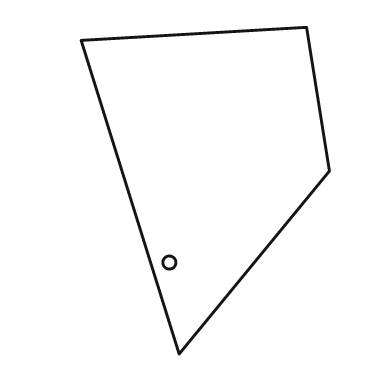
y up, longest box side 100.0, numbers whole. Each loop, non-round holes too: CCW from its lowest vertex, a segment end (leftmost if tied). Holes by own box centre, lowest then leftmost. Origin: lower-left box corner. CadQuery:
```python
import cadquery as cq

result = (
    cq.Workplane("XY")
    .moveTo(30.0, 0.0)
    .lineTo(76.0, 56.0)
    .lineTo(69.0, 100.0)
    .lineTo(0.0, 96.0)
    .close()
    .moveTo(27.0, 28.0)
    .circle(2.0)
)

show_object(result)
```